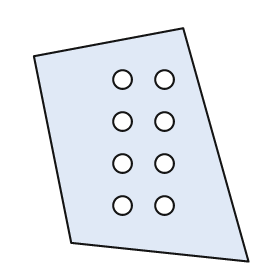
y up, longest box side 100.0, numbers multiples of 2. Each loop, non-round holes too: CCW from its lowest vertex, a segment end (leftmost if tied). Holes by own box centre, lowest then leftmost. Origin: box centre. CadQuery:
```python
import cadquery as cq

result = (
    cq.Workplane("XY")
    .moveTo(46.0, -50.0)
    .lineTo(18.0, 50.0)
    .lineTo(-46.0, 38.0)
    .lineTo(-30.0, -42.0)
    .close()
    .moveTo(-8.0, -26.0)
    .circle(4.0)
    .moveTo(10.0, -26.0)
    .circle(4.0)
    .moveTo(-8.0, -8.0)
    .circle(4.0)
    .moveTo(10.0, -8.0)
    .circle(4.0)
    .moveTo(-8.0, 10.0)
    .circle(4.0)
    .moveTo(10.0, 10.0)
    .circle(4.0)
    .moveTo(-8.0, 28.0)
    .circle(4.0)
    .moveTo(10.0, 28.0)
    .circle(4.0)
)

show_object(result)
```